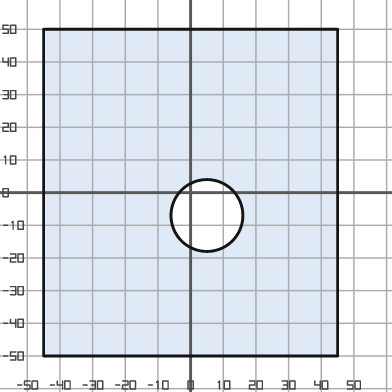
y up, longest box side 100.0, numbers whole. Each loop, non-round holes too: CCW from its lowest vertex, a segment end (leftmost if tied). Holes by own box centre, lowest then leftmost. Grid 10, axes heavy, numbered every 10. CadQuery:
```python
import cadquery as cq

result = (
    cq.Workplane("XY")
    .moveTo(-45.0, -50.0)
    .lineTo(45.0, -50.0)
    .lineTo(45.0, 50.0)
    .lineTo(-45.0, 50.0)
    .close()
    .moveTo(5.0, -7.0)
    .circle(11.0)
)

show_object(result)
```